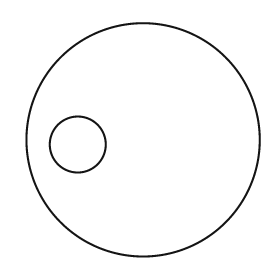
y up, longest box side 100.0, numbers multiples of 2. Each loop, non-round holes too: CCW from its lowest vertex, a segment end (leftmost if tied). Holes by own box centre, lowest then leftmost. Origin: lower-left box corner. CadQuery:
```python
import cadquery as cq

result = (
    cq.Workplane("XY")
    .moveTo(50.0, 50.0)
    .circle(50.0)
    .moveTo(22.0, 48.0)
    .circle(12.0)
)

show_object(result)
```